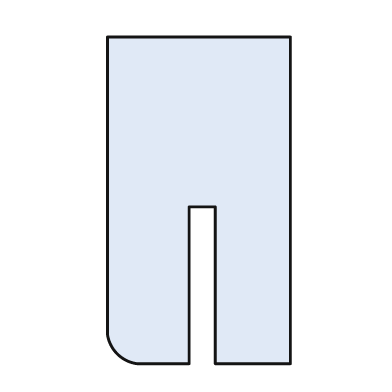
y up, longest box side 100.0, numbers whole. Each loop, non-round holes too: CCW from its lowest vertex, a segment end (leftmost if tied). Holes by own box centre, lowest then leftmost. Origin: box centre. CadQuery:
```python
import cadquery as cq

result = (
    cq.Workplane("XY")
    .moveTo(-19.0, -50.0)
    .lineTo(-3.0, -50.0)
    .lineTo(-3.0, -2.0)
    .lineTo(5.0, -2.0)
    .lineTo(5.0, -50.0)
    .lineTo(28.0, -50.0)
    .lineTo(28.0, 50.0)
    .lineTo(-28.0, 50.0)
    .lineTo(-28.0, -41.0)
    .threePointArc((-25.0, -47.0), (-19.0, -50.0))
    .close()
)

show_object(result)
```